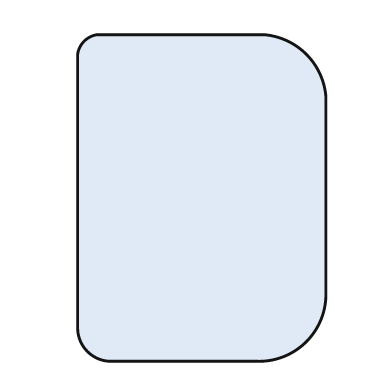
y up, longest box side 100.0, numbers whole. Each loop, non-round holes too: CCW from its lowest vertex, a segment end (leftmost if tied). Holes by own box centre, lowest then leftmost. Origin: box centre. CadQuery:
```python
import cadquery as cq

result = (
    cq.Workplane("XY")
    .moveTo(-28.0, -50.0)
    .lineTo(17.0, -50.0)
    .threePointArc((32.0, -44.0), (38.0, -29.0))
    .lineTo(38.0, 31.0)
    .threePointArc((32.0, 44.0), (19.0, 50.0))
    .lineTo(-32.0, 50.0)
    .threePointArc((-36.0, 48.0), (-38.0, 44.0))
    .lineTo(-38.0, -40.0)
    .threePointArc((-35.0, -47.0), (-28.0, -50.0))
    .close()
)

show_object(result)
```